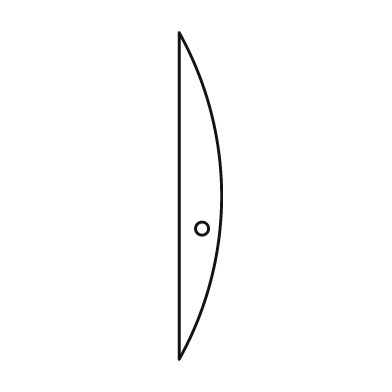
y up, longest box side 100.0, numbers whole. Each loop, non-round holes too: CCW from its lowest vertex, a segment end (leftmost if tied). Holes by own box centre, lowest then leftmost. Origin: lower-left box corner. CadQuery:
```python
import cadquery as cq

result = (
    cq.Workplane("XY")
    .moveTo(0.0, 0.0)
    .threePointArc((13.0, 50.0), (0.0, 100.0))
    .close()
    .moveTo(7.0, 40.0)
    .circle(2.0)
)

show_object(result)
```